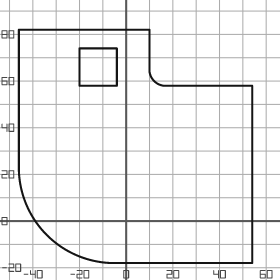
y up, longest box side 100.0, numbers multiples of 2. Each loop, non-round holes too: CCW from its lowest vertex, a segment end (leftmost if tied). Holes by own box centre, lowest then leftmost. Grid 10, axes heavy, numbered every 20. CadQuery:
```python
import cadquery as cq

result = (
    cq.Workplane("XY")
    .moveTo(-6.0, -18.0)
    .lineTo(54.0, -18.0)
    .lineTo(54.0, 58.0)
    .lineTo(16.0, 58.0)
    .threePointArc((12.0, 60.0), (10.0, 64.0))
    .lineTo(10.0, 82.0)
    .lineTo(-46.0, 82.0)
    .lineTo(-46.0, 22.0)
    .threePointArc((-34.0, -6.0), (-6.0, -18.0))
    .close()
    .moveTo(-20.0, 58.0)
    .lineTo(-4.0, 58.0)
    .lineTo(-4.0, 74.0)
    .lineTo(-20.0, 74.0)
    .close()
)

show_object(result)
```